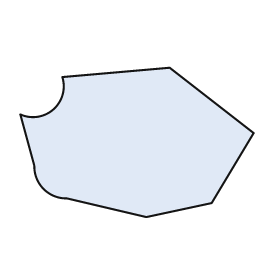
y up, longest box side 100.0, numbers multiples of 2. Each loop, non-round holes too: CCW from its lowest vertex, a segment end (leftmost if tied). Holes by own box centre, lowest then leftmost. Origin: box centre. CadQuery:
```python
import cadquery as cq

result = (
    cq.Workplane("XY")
    .moveTo(4.0, -32.0)
    .lineTo(32.0, -26.0)
    .lineTo(50.0, 4.0)
    .lineTo(14.0, 32.0)
    .lineTo(-32.0, 28.0)
    .threePointArc((-36.0, 14.0), (-50.0, 12.0))
    .lineTo(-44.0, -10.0)
    .threePointArc((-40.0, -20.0), (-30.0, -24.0))
    .close()
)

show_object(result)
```